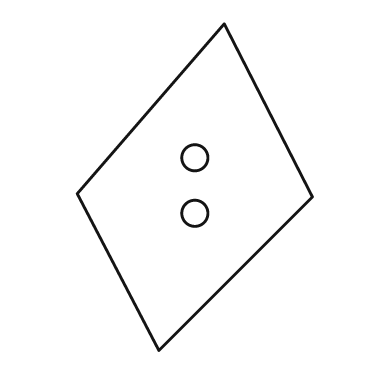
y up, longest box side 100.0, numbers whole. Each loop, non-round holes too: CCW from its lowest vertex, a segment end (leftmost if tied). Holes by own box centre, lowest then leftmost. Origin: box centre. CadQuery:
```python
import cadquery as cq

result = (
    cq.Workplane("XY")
    .moveTo(-11.0, -50.0)
    .lineTo(36.0, -3.0)
    .lineTo(9.0, 50.0)
    .lineTo(-36.0, -2.0)
    .close()
    .moveTo(0.0, -8.0)
    .circle(4.0)
    .moveTo(0.0, 9.0)
    .circle(4.0)
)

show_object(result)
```